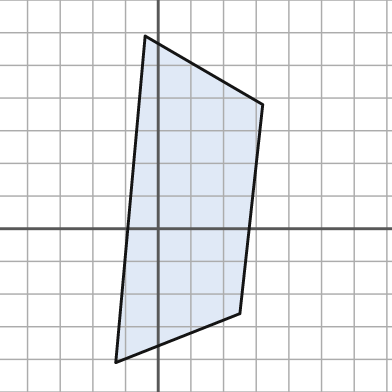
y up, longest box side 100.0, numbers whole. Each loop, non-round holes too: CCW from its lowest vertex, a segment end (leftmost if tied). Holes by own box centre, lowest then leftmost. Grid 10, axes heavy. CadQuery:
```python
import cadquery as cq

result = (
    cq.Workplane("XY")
    .moveTo(-13.0, -41.0)
    .lineTo(25.0, -26.0)
    .lineTo(32.0, 38.0)
    .lineTo(-4.0, 59.0)
    .close()
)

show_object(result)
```